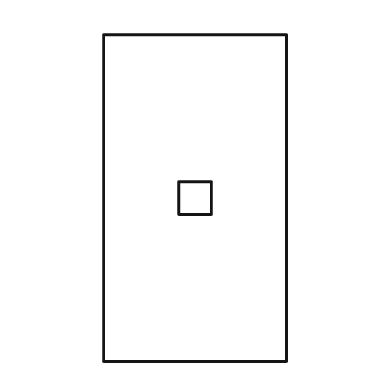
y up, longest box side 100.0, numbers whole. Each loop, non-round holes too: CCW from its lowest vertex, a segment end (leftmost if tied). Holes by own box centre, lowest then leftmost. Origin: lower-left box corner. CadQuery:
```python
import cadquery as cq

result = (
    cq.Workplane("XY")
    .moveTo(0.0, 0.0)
    .lineTo(56.0, 0.0)
    .lineTo(56.0, 100.0)
    .lineTo(0.0, 100.0)
    .close()
    .moveTo(23.0, 45.0)
    .lineTo(33.0, 45.0)
    .lineTo(33.0, 55.0)
    .lineTo(23.0, 55.0)
    .close()
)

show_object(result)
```